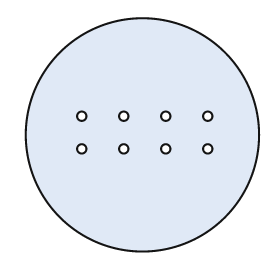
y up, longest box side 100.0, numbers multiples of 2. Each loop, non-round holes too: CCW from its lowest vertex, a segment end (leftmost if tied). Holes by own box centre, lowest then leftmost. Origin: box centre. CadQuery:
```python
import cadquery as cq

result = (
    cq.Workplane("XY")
    .moveTo(0.0, 0.0)
    .circle(50.0)
    .moveTo(-26.0, -6.0)
    .circle(2.0)
    .moveTo(-8.0, -6.0)
    .circle(2.0)
    .moveTo(10.0, -6.0)
    .circle(2.0)
    .moveTo(28.0, -6.0)
    .circle(2.0)
    .moveTo(-26.0, 8.0)
    .circle(2.0)
    .moveTo(-8.0, 8.0)
    .circle(2.0)
    .moveTo(10.0, 8.0)
    .circle(2.0)
    .moveTo(28.0, 8.0)
    .circle(2.0)
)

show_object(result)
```